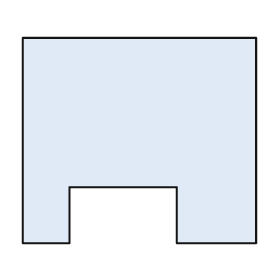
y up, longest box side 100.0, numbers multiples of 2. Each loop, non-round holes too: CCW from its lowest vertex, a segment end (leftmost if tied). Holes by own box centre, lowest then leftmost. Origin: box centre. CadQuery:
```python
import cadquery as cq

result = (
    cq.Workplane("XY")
    .moveTo(-50.0, -44.0)
    .lineTo(-30.0, -44.0)
    .lineTo(-30.0, -20.0)
    .lineTo(16.0, -20.0)
    .lineTo(16.0, -44.0)
    .lineTo(50.0, -44.0)
    .lineTo(50.0, 44.0)
    .lineTo(-50.0, 44.0)
    .close()
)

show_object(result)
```